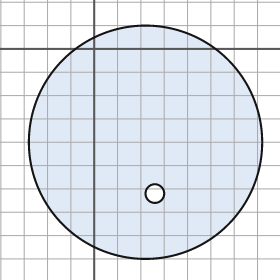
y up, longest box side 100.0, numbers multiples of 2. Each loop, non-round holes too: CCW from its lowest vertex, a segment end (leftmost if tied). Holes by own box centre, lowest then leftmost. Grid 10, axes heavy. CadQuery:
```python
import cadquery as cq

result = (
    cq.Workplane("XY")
    .moveTo(22.0, -40.0)
    .circle(50.0)
    .moveTo(26.0, -62.0)
    .circle(4.0)
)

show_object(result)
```